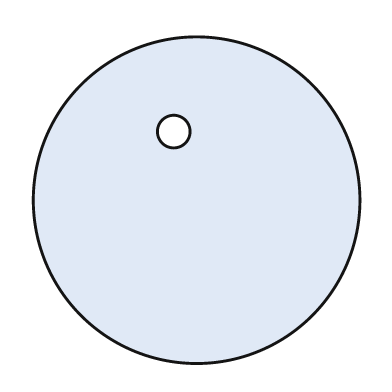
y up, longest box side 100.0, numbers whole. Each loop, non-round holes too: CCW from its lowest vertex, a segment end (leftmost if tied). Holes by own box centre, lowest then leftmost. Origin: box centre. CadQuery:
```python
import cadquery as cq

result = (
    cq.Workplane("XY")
    .moveTo(0.0, 0.0)
    .circle(50.0)
    .moveTo(-7.0, 21.0)
    .circle(5.0)
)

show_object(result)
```